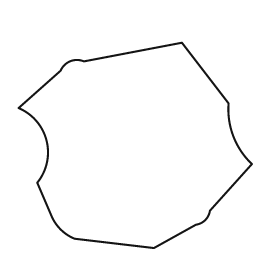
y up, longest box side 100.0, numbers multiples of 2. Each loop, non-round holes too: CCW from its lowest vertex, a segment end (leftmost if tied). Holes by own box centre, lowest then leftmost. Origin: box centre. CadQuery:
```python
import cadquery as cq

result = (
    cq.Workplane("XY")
    .moveTo(8.0, -44.0)
    .lineTo(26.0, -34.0)
    .threePointArc((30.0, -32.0), (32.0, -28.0))
    .lineTo(50.0, -8.0)
    .threePointArc((42.0, 4.0), (40.0, 18.0))
    .lineTo(20.0, 44.0)
    .lineTo(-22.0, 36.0)
    .threePointArc((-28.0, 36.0), (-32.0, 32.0))
    .lineTo(-50.0, 16.0)
    .threePointArc((-38.0, 2.0), (-42.0, -16.0))
    .lineTo(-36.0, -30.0)
    .threePointArc((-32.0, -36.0), (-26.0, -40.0))
    .close()
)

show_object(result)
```